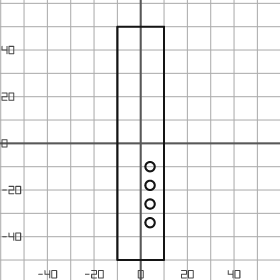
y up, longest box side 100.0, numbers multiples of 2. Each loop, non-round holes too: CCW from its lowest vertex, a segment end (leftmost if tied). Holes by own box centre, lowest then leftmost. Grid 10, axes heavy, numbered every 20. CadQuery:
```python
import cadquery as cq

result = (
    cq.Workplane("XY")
    .moveTo(-10.0, -50.0)
    .lineTo(10.0, -50.0)
    .lineTo(10.0, 50.0)
    .lineTo(-10.0, 50.0)
    .close()
    .moveTo(4.0, -34.0)
    .circle(2.0)
    .moveTo(4.0, -26.0)
    .circle(2.0)
    .moveTo(4.0, -18.0)
    .circle(2.0)
    .moveTo(4.0, -10.0)
    .circle(2.0)
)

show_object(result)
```